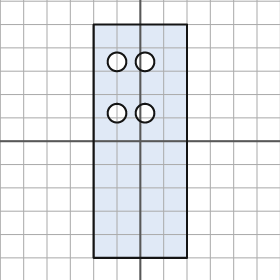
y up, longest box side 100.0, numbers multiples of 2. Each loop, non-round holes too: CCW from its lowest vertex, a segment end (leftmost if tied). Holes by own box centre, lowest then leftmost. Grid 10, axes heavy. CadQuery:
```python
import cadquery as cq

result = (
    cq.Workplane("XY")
    .moveTo(-20.0, -50.0)
    .lineTo(20.0, -50.0)
    .lineTo(20.0, 50.0)
    .lineTo(-20.0, 50.0)
    .close()
    .moveTo(-10.0, 12.0)
    .circle(4.0)
    .moveTo(2.0, 12.0)
    .circle(4.0)
    .moveTo(-10.0, 34.0)
    .circle(4.0)
    .moveTo(2.0, 34.0)
    .circle(4.0)
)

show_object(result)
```